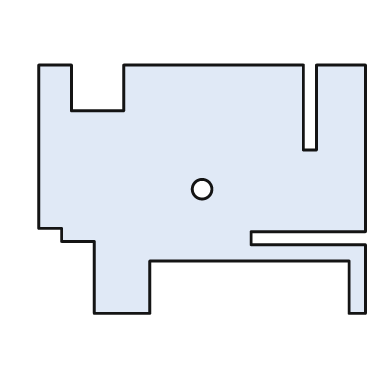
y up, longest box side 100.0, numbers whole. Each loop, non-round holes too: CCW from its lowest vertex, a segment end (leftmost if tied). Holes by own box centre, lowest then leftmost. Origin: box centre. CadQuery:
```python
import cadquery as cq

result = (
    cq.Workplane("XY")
    .moveTo(-33.0, -38.0)
    .lineTo(-16.0, -38.0)
    .lineTo(-16.0, -22.0)
    .lineTo(45.0, -22.0)
    .lineTo(45.0, -38.0)
    .lineTo(50.0, -38.0)
    .lineTo(50.0, -17.0)
    .lineTo(15.0, -17.0)
    .lineTo(15.0, -13.0)
    .lineTo(50.0, -13.0)
    .lineTo(50.0, 38.0)
    .lineTo(35.0, 38.0)
    .lineTo(35.0, 12.0)
    .lineTo(31.0, 12.0)
    .lineTo(31.0, 38.0)
    .lineTo(-24.0, 38.0)
    .lineTo(-24.0, 24.0)
    .lineTo(-40.0, 24.0)
    .lineTo(-40.0, 38.0)
    .lineTo(-50.0, 38.0)
    .lineTo(-50.0, -12.0)
    .lineTo(-43.0, -12.0)
    .lineTo(-43.0, -16.0)
    .lineTo(-33.0, -16.0)
    .close()
    .moveTo(0.0, 0.0)
    .circle(3.0)
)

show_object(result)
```